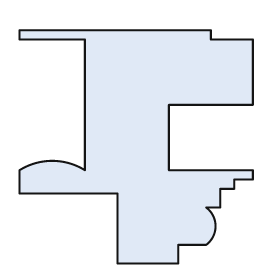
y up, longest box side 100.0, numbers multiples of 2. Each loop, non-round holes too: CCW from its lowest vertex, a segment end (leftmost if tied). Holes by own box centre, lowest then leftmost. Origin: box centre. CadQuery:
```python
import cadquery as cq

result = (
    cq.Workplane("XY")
    .moveTo(-8.0, -50.0)
    .lineTo(18.0, -50.0)
    .lineTo(18.0, -42.0)
    .lineTo(30.0, -42.0)
    .threePointArc((34.0, -34.0), (30.0, -26.0))
    .lineTo(36.0, -26.0)
    .lineTo(36.0, -18.0)
    .lineTo(42.0, -18.0)
    .lineTo(42.0, -14.0)
    .lineTo(50.0, -14.0)
    .lineTo(50.0, -10.0)
    .lineTo(14.0, -10.0)
    .lineTo(14.0, 18.0)
    .lineTo(50.0, 18.0)
    .lineTo(50.0, 46.0)
    .lineTo(32.0, 46.0)
    .lineTo(32.0, 50.0)
    .lineTo(-50.0, 50.0)
    .lineTo(-50.0, 46.0)
    .lineTo(-22.0, 46.0)
    .lineTo(-22.0, -10.0)
    .threePointArc((-36.0, -6.0), (-50.0, -10.0))
    .lineTo(-50.0, -20.0)
    .lineTo(-8.0, -20.0)
    .close()
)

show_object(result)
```